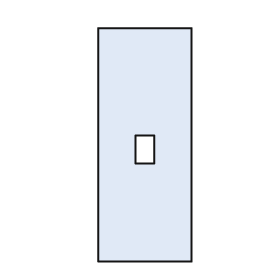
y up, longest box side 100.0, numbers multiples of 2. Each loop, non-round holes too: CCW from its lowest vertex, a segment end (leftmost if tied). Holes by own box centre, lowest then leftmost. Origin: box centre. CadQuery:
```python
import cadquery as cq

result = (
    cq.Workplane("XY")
    .moveTo(-20.0, -50.0)
    .lineTo(20.0, -50.0)
    .lineTo(20.0, 50.0)
    .lineTo(-20.0, 50.0)
    .close()
    .moveTo(-4.0, -8.0)
    .lineTo(4.0, -8.0)
    .lineTo(4.0, 4.0)
    .lineTo(-4.0, 4.0)
    .close()
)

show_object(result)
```